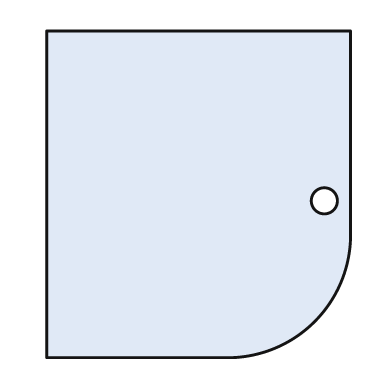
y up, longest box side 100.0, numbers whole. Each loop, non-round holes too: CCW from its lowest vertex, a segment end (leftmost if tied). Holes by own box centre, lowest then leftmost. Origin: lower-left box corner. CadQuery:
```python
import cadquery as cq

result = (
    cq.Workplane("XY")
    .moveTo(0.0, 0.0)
    .lineTo(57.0, 0.0)
    .threePointArc((82.0, 11.0), (93.0, 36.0))
    .lineTo(93.0, 100.0)
    .lineTo(0.0, 100.0)
    .close()
    .moveTo(85.0, 48.0)
    .circle(4.0)
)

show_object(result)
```